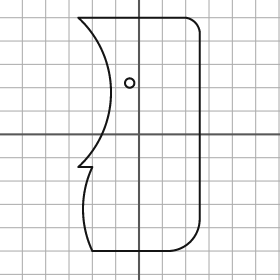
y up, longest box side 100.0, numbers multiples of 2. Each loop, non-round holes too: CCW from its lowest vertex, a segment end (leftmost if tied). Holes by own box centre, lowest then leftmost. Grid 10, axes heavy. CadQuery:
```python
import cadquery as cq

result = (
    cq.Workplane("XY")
    .moveTo(-20.0, -50.0)
    .lineTo(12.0, -50.0)
    .threePointArc((22.0, -46.0), (26.0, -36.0))
    .lineTo(26.0, 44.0)
    .threePointArc((24.0, 48.0), (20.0, 50.0))
    .lineTo(-26.0, 50.0)
    .threePointArc((-12.0, 18.0), (-26.0, -14.0))
    .lineTo(-20.0, -14.0)
    .threePointArc((-24.0, -32.0), (-20.0, -50.0))
    .close()
    .moveTo(-4.0, 22.0)
    .circle(2.0)
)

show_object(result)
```